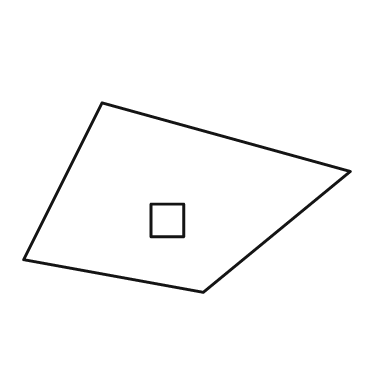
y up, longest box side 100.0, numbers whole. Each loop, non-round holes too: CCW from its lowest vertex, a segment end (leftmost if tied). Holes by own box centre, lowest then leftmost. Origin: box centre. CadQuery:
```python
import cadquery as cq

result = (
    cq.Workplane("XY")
    .moveTo(5.0, -29.0)
    .lineTo(50.0, 8.0)
    .lineTo(-26.0, 29.0)
    .lineTo(-50.0, -19.0)
    .close()
    .moveTo(-11.0, -12.0)
    .lineTo(-1.0, -12.0)
    .lineTo(-1.0, -2.0)
    .lineTo(-11.0, -2.0)
    .close()
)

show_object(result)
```